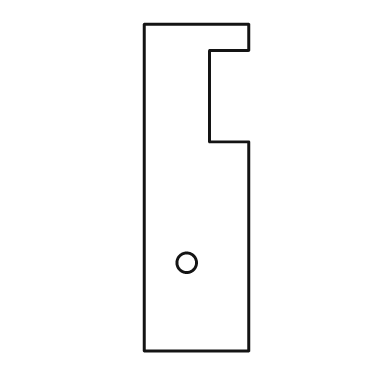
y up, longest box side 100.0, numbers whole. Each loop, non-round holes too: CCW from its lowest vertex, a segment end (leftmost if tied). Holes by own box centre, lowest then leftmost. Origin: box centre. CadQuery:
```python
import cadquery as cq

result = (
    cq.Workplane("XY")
    .moveTo(-16.0, -50.0)
    .lineTo(16.0, -50.0)
    .lineTo(16.0, 14.0)
    .lineTo(4.0, 14.0)
    .lineTo(4.0, 42.0)
    .lineTo(16.0, 42.0)
    .lineTo(16.0, 50.0)
    .lineTo(-16.0, 50.0)
    .close()
    .moveTo(-3.0, -23.0)
    .circle(3.0)
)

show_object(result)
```